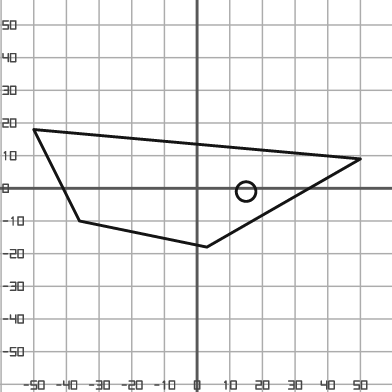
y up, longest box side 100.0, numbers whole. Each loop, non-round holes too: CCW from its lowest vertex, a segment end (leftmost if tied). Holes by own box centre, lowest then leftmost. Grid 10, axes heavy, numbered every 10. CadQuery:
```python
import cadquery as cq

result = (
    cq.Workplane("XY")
    .moveTo(3.0, -18.0)
    .lineTo(50.0, 9.0)
    .lineTo(-50.0, 18.0)
    .lineTo(-36.0, -10.0)
    .close()
    .moveTo(15.0, -1.0)
    .circle(3.0)
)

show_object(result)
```